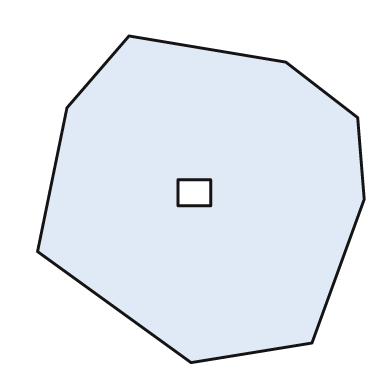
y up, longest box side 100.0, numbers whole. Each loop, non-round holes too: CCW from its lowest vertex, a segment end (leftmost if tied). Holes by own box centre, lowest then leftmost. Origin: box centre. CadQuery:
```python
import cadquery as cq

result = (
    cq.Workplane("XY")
    .moveTo(-3.0, -50.0)
    .lineTo(34.0, -44.0)
    .lineTo(50.0, 0.0)
    .lineTo(48.0, 25.0)
    .lineTo(26.0, 42.0)
    .lineTo(-22.0, 50.0)
    .lineTo(-41.0, 28.0)
    .lineTo(-50.0, -16.0)
    .close()
    .moveTo(-7.0, -2.0)
    .lineTo(3.0, -2.0)
    .lineTo(3.0, 6.0)
    .lineTo(-7.0, 6.0)
    .close()
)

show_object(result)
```